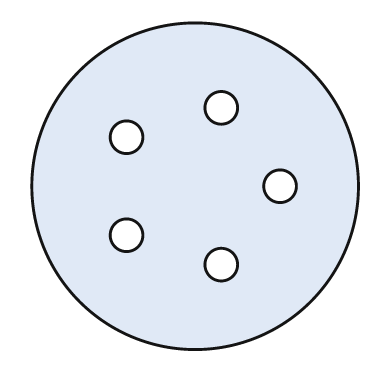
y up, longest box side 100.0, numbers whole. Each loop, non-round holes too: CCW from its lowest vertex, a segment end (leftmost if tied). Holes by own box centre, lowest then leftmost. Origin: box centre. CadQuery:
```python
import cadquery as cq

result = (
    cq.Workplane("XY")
    .moveTo(0.0, 0.0)
    .circle(50.0)
    .moveTo(8.0, -24.0)
    .circle(5.0)
    .moveTo(-21.0, -15.0)
    .circle(5.0)
    .moveTo(26.0, 0.0)
    .circle(5.0)
    .moveTo(-21.0, 15.0)
    .circle(5.0)
    .moveTo(8.0, 24.0)
    .circle(5.0)
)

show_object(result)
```